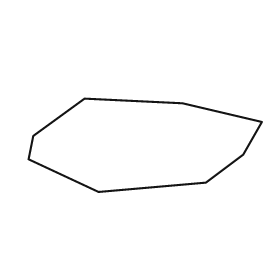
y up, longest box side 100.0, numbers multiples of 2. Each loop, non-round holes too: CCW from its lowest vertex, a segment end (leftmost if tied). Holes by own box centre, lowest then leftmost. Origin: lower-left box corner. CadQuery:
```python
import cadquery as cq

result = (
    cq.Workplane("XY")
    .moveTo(30.0, 0.0)
    .lineTo(76.0, 4.0)
    .lineTo(92.0, 16.0)
    .lineTo(100.0, 30.0)
    .lineTo(66.0, 38.0)
    .lineTo(24.0, 40.0)
    .lineTo(2.0, 24.0)
    .lineTo(0.0, 14.0)
    .close()
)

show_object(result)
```